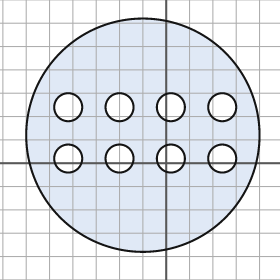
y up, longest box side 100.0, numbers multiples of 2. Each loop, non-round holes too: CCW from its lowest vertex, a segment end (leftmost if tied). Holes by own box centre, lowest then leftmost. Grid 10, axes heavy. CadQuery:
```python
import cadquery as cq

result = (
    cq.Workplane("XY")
    .moveTo(-10.0, 12.0)
    .circle(50.0)
    .moveTo(-42.0, 2.0)
    .circle(6.0)
    .moveTo(-20.0, 2.0)
    .circle(6.0)
    .moveTo(2.0, 2.0)
    .circle(6.0)
    .moveTo(24.0, 2.0)
    .circle(6.0)
    .moveTo(-42.0, 24.0)
    .circle(6.0)
    .moveTo(-20.0, 24.0)
    .circle(6.0)
    .moveTo(2.0, 24.0)
    .circle(6.0)
    .moveTo(24.0, 24.0)
    .circle(6.0)
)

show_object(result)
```